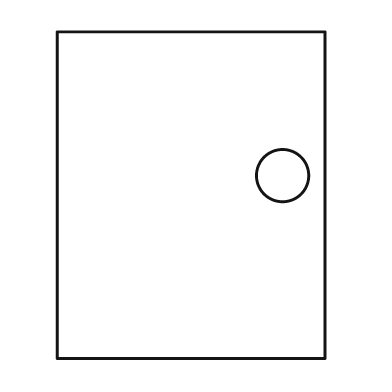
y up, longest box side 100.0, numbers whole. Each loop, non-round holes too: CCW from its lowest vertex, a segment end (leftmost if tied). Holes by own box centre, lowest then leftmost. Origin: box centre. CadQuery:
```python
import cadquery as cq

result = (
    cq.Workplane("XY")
    .moveTo(-41.0, -50.0)
    .lineTo(41.0, -50.0)
    .lineTo(41.0, 50.0)
    .lineTo(-41.0, 50.0)
    .close()
    .moveTo(28.0, 6.0)
    .circle(8.0)
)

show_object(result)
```